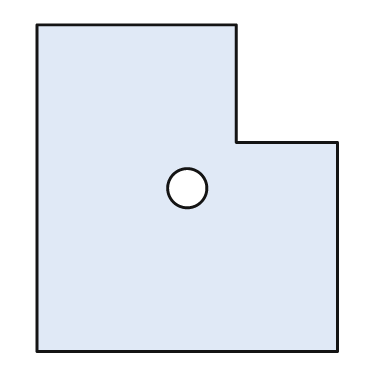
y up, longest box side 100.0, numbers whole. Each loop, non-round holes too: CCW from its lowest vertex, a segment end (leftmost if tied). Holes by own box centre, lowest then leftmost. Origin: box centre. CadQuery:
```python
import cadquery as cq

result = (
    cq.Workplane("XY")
    .moveTo(-46.0, -50.0)
    .lineTo(46.0, -50.0)
    .lineTo(46.0, 14.0)
    .lineTo(15.0, 14.0)
    .lineTo(15.0, 50.0)
    .lineTo(-46.0, 50.0)
    .close()
    .moveTo(0.0, 0.0)
    .circle(6.0)
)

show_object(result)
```